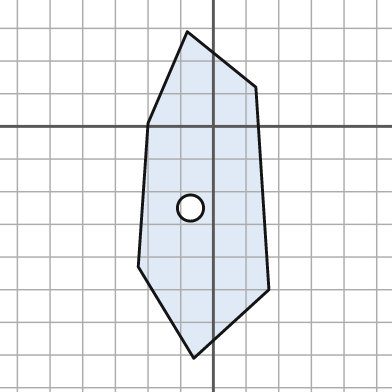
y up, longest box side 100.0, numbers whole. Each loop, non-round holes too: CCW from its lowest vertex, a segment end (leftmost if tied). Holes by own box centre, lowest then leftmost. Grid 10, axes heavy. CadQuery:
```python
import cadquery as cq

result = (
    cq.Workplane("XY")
    .moveTo(-6.0, -71.0)
    .lineTo(17.0, -50.0)
    .lineTo(13.0, 12.0)
    .lineTo(-8.0, 29.0)
    .lineTo(-20.0, 1.0)
    .lineTo(-23.0, -43.0)
    .close()
    .moveTo(-7.0, -25.0)
    .circle(4.0)
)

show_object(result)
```